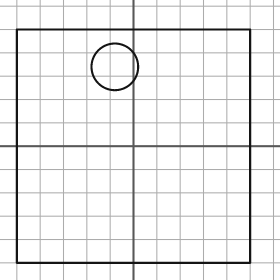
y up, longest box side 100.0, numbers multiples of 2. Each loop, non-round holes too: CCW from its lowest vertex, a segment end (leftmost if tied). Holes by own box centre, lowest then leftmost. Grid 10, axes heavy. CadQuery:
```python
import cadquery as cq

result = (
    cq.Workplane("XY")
    .moveTo(-50.0, -50.0)
    .lineTo(50.0, -50.0)
    .lineTo(50.0, 50.0)
    .lineTo(-50.0, 50.0)
    .close()
    .moveTo(-8.0, 34.0)
    .circle(10.0)
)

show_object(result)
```